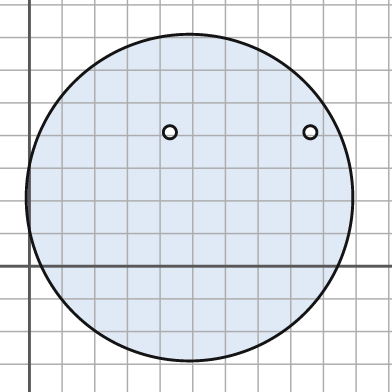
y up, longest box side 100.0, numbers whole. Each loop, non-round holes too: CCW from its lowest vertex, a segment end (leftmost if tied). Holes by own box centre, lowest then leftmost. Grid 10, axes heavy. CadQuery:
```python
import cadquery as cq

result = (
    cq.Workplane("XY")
    .moveTo(49.0, 21.0)
    .circle(50.0)
    .moveTo(43.0, 41.0)
    .circle(2.0)
    .moveTo(86.0, 41.0)
    .circle(2.0)
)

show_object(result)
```